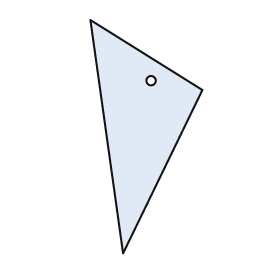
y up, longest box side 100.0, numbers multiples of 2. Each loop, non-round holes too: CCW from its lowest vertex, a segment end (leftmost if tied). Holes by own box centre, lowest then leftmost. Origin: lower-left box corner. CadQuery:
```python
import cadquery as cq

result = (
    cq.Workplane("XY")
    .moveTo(14.0, 0.0)
    .lineTo(48.0, 70.0)
    .lineTo(0.0, 100.0)
    .close()
    .moveTo(26.0, 74.0)
    .circle(2.0)
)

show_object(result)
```